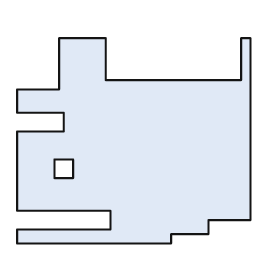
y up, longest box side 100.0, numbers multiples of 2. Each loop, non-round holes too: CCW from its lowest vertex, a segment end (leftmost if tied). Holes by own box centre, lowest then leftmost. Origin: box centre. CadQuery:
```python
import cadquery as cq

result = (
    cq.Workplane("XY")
    .moveTo(-50.0, -44.0)
    .lineTo(16.0, -44.0)
    .lineTo(16.0, -40.0)
    .lineTo(32.0, -40.0)
    .lineTo(32.0, -34.0)
    .lineTo(50.0, -34.0)
    .lineTo(50.0, 44.0)
    .lineTo(46.0, 44.0)
    .lineTo(46.0, 26.0)
    .lineTo(-12.0, 26.0)
    .lineTo(-12.0, 44.0)
    .lineTo(-32.0, 44.0)
    .lineTo(-32.0, 22.0)
    .lineTo(-50.0, 22.0)
    .lineTo(-50.0, 12.0)
    .lineTo(-30.0, 12.0)
    .lineTo(-30.0, 4.0)
    .lineTo(-50.0, 4.0)
    .lineTo(-50.0, -30.0)
    .lineTo(-10.0, -30.0)
    .lineTo(-10.0, -38.0)
    .lineTo(-50.0, -38.0)
    .close()
    .moveTo(-34.0, -16.0)
    .lineTo(-26.0, -16.0)
    .lineTo(-26.0, -8.0)
    .lineTo(-34.0, -8.0)
    .close()
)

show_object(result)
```